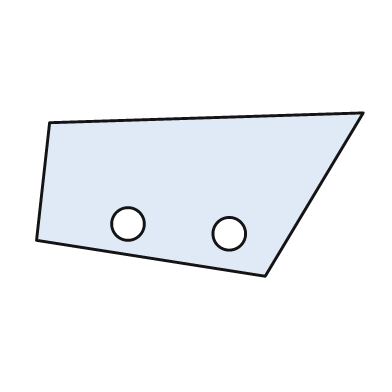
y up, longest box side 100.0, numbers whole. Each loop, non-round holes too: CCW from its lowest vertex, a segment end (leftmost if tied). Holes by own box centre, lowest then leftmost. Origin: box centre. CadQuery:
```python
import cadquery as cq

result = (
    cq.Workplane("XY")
    .moveTo(20.0, -25.0)
    .lineTo(50.0, 25.0)
    .lineTo(-46.0, 22.0)
    .lineTo(-50.0, -14.0)
    .close()
    .moveTo(9.0, -12.0)
    .circle(5.0)
    .moveTo(-22.0, -9.0)
    .circle(5.0)
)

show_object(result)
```